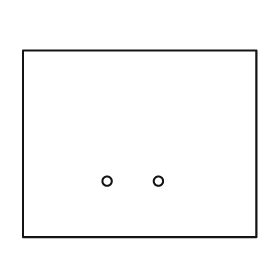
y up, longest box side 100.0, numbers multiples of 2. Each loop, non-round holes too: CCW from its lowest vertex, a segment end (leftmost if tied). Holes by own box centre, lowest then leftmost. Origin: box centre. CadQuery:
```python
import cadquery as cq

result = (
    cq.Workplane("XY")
    .moveTo(-50.0, -40.0)
    .lineTo(50.0, -40.0)
    .lineTo(50.0, 40.0)
    .lineTo(-50.0, 40.0)
    .close()
    .moveTo(-14.0, -16.0)
    .circle(2.0)
    .moveTo(8.0, -16.0)
    .circle(2.0)
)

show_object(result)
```